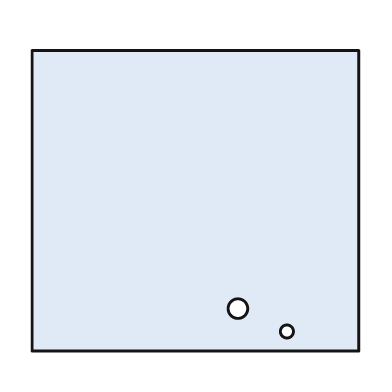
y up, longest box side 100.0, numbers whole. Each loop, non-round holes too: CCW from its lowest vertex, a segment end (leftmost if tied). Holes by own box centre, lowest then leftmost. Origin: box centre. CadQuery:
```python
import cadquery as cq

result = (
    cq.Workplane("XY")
    .moveTo(-50.0, -46.0)
    .lineTo(50.0, -46.0)
    .lineTo(50.0, 46.0)
    .lineTo(-50.0, 46.0)
    .close()
    .moveTo(28.0, -40.0)
    .circle(2.0)
    .moveTo(13.0, -33.0)
    .circle(3.0)
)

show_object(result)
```